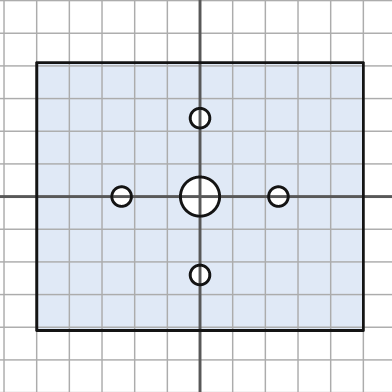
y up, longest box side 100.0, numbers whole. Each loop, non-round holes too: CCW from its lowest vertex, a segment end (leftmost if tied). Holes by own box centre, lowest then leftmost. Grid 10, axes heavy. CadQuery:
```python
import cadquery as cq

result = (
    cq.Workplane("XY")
    .moveTo(-50.0, -41.0)
    .lineTo(50.0, -41.0)
    .lineTo(50.0, 41.0)
    .lineTo(-50.0, 41.0)
    .close()
    .moveTo(0.0, -24.0)
    .circle(3.0)
    .moveTo(-24.0, 0.0)
    .circle(3.0)
    .moveTo(0.0, 0.0)
    .circle(6.0)
    .moveTo(24.0, 0.0)
    .circle(3.0)
    .moveTo(0.0, 24.0)
    .circle(3.0)
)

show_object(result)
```